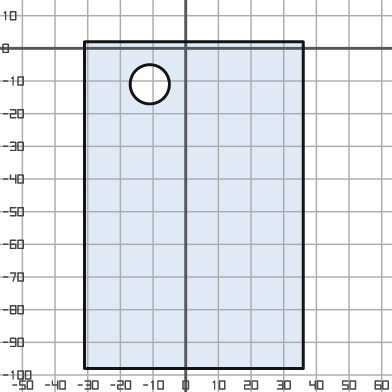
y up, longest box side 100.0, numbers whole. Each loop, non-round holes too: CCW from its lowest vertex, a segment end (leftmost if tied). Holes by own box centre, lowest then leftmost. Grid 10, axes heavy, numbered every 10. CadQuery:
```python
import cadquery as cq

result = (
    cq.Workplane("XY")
    .moveTo(-31.0, -98.0)
    .lineTo(36.0, -98.0)
    .lineTo(36.0, 2.0)
    .lineTo(-31.0, 2.0)
    .close()
    .moveTo(-11.0, -11.0)
    .circle(6.0)
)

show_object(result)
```